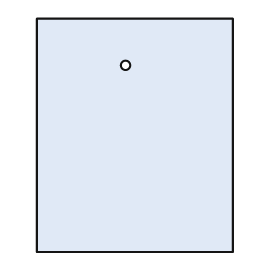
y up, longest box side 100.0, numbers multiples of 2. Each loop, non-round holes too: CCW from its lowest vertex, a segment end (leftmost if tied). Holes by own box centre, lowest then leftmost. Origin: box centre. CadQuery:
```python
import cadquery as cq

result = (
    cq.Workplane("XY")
    .moveTo(-42.0, -50.0)
    .lineTo(42.0, -50.0)
    .lineTo(42.0, 50.0)
    .lineTo(-42.0, 50.0)
    .close()
    .moveTo(-4.0, 30.0)
    .circle(2.0)
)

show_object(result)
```